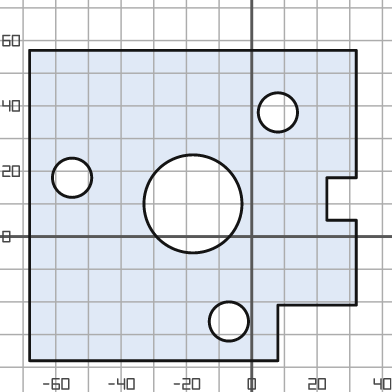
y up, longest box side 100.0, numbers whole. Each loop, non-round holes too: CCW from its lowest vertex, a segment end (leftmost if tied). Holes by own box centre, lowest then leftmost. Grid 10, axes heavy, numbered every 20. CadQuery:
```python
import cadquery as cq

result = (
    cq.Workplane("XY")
    .moveTo(-68.0, -38.0)
    .lineTo(8.0, -38.0)
    .lineTo(8.0, -21.0)
    .lineTo(32.0, -21.0)
    .lineTo(32.0, 5.0)
    .lineTo(23.0, 5.0)
    .lineTo(23.0, 18.0)
    .lineTo(32.0, 18.0)
    .lineTo(32.0, 57.0)
    .lineTo(-68.0, 57.0)
    .close()
    .moveTo(-7.0, -26.0)
    .circle(6.0)
    .moveTo(-18.0, 10.0)
    .circle(15.0)
    .moveTo(-55.0, 18.0)
    .circle(6.0)
    .moveTo(8.0, 38.0)
    .circle(6.0)
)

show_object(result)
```